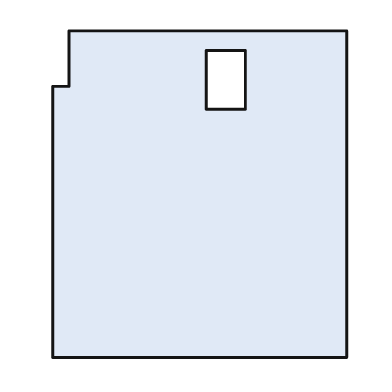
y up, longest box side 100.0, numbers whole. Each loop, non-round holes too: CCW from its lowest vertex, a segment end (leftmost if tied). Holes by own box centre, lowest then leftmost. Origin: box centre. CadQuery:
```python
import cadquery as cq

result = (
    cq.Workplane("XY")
    .moveTo(-45.0, -50.0)
    .lineTo(45.0, -50.0)
    .lineTo(45.0, 50.0)
    .lineTo(-40.0, 50.0)
    .lineTo(-40.0, 33.0)
    .lineTo(-45.0, 33.0)
    .close()
    .moveTo(2.0, 26.0)
    .lineTo(14.0, 26.0)
    .lineTo(14.0, 44.0)
    .lineTo(2.0, 44.0)
    .close()
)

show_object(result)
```